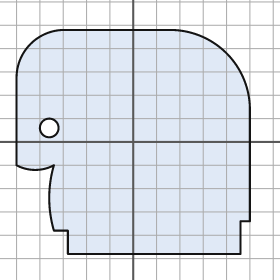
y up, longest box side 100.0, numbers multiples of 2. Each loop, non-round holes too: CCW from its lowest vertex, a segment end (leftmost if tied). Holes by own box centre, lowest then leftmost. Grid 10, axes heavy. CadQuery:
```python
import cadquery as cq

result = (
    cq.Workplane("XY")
    .moveTo(-28.0, -48.0)
    .lineTo(46.0, -48.0)
    .lineTo(46.0, -34.0)
    .lineTo(50.0, -34.0)
    .lineTo(50.0, 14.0)
    .threePointArc((40.0, 38.0), (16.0, 48.0))
    .lineTo(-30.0, 48.0)
    .threePointArc((-44.0, 42.0), (-50.0, 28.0))
    .lineTo(-50.0, -10.0)
    .threePointArc((-42.0, -12.0), (-34.0, -10.0))
    .threePointArc((-36.0, -24.0), (-34.0, -38.0))
    .lineTo(-28.0, -38.0)
    .close()
    .moveTo(-36.0, 6.0)
    .circle(4.0)
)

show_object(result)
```